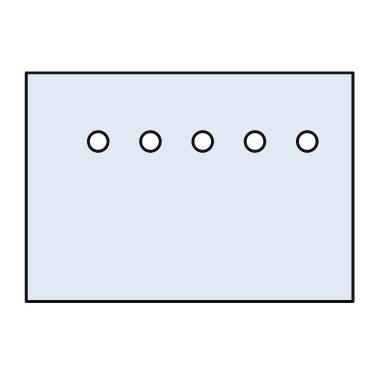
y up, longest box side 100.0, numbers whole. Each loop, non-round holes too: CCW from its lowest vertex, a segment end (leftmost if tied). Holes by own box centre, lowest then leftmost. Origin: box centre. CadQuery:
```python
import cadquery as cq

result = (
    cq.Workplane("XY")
    .moveTo(-50.0, -35.0)
    .lineTo(50.0, -35.0)
    .lineTo(50.0, 35.0)
    .lineTo(-50.0, 35.0)
    .close()
    .moveTo(-28.0, 14.0)
    .circle(3.0)
    .moveTo(-12.0, 14.0)
    .circle(3.0)
    .moveTo(4.0, 14.0)
    .circle(3.0)
    .moveTo(20.0, 14.0)
    .circle(3.0)
    .moveTo(36.0, 14.0)
    .circle(3.0)
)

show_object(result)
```